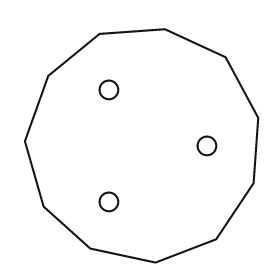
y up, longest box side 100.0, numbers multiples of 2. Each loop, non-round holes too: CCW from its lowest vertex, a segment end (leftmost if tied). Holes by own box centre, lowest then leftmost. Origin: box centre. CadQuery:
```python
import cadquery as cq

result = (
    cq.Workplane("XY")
    .moveTo(6.0, -50.0)
    .lineTo(32.0, -40.0)
    .lineTo(48.0, -16.0)
    .lineTo(50.0, 12.0)
    .lineTo(36.0, 38.0)
    .lineTo(10.0, 50.0)
    .lineTo(-18.0, 48.0)
    .lineTo(-40.0, 30.0)
    .lineTo(-50.0, 2.0)
    .lineTo(-42.0, -26.0)
    .lineTo(-22.0, -44.0)
    .close()
    .moveTo(-14.0, -24.0)
    .circle(4.0)
    .moveTo(28.0, 0.0)
    .circle(4.0)
    .moveTo(-14.0, 24.0)
    .circle(4.0)
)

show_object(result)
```